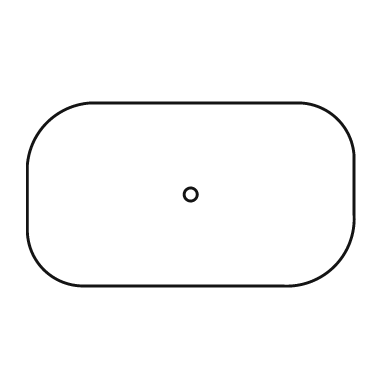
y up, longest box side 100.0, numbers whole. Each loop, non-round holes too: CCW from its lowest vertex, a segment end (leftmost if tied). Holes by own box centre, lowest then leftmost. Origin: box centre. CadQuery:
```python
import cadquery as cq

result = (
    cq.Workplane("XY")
    .moveTo(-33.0, -28.0)
    .lineTo(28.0, -28.0)
    .threePointArc((44.0, -22.0), (50.0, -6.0))
    .lineTo(50.0, 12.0)
    .threePointArc((45.0, 23.0), (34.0, 28.0))
    .lineTo(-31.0, 28.0)
    .threePointArc((-44.0, 22.0), (-50.0, 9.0))
    .lineTo(-50.0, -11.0)
    .threePointArc((-45.0, -23.0), (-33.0, -28.0))
    .close()
    .moveTo(0.0, 0.0)
    .circle(2.0)
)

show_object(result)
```